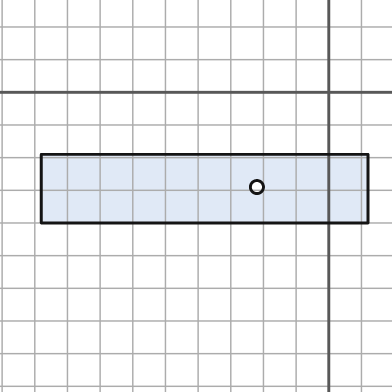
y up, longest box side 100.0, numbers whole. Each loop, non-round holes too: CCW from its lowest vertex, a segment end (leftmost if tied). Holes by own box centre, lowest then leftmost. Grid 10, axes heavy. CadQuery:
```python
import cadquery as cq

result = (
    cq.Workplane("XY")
    .moveTo(-88.0, -40.0)
    .lineTo(12.0, -40.0)
    .lineTo(12.0, -19.0)
    .lineTo(-88.0, -19.0)
    .close()
    .moveTo(-22.0, -29.0)
    .circle(2.0)
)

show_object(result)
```